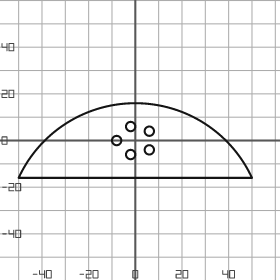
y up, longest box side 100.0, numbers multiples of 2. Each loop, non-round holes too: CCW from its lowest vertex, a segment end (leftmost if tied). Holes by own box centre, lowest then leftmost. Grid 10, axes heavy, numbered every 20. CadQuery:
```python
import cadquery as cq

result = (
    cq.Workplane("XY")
    .moveTo(-50.0, -16.0)
    .lineTo(50.0, -16.0)
    .threePointArc((0.0, 16.0), (-50.0, -16.0))
    .close()
    .moveTo(-2.0, -6.0)
    .circle(2.0)
    .moveTo(6.0, -4.0)
    .circle(2.0)
    .moveTo(-8.0, 0.0)
    .circle(2.0)
    .moveTo(6.0, 4.0)
    .circle(2.0)
    .moveTo(-2.0, 6.0)
    .circle(2.0)
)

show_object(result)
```